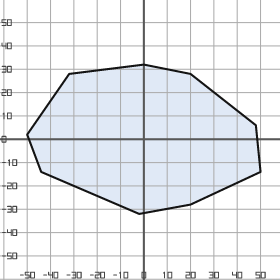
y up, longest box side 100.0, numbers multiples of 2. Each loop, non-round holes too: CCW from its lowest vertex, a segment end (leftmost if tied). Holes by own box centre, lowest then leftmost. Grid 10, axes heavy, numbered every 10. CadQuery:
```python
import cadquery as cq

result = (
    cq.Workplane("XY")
    .moveTo(-2.0, -32.0)
    .lineTo(20.0, -28.0)
    .lineTo(50.0, -14.0)
    .lineTo(48.0, 6.0)
    .lineTo(20.0, 28.0)
    .lineTo(0.0, 32.0)
    .lineTo(-32.0, 28.0)
    .lineTo(-50.0, 2.0)
    .lineTo(-44.0, -14.0)
    .close()
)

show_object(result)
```